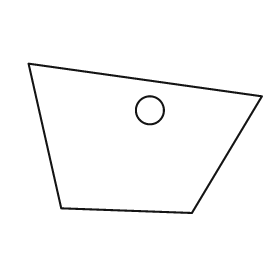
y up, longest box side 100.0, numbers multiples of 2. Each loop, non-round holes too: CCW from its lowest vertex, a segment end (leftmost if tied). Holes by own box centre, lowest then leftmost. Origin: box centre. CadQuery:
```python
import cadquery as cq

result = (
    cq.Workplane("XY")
    .moveTo(20.0, -32.0)
    .lineTo(50.0, 18.0)
    .lineTo(-50.0, 32.0)
    .lineTo(-36.0, -30.0)
    .close()
    .moveTo(2.0, 12.0)
    .circle(6.0)
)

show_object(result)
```